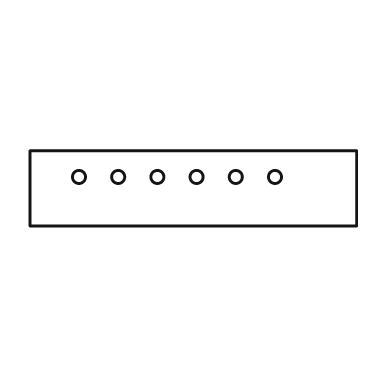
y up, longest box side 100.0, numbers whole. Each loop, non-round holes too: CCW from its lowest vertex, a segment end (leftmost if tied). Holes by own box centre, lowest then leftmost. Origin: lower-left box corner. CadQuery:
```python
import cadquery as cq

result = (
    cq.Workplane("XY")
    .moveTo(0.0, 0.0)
    .lineTo(100.0, 0.0)
    .lineTo(100.0, 23.0)
    .lineTo(0.0, 23.0)
    .close()
    .moveTo(15.0, 15.0)
    .circle(2.0)
    .moveTo(27.0, 15.0)
    .circle(2.0)
    .moveTo(39.0, 15.0)
    .circle(2.0)
    .moveTo(51.0, 15.0)
    .circle(2.0)
    .moveTo(63.0, 15.0)
    .circle(2.0)
    .moveTo(75.0, 15.0)
    .circle(2.0)
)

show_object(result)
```